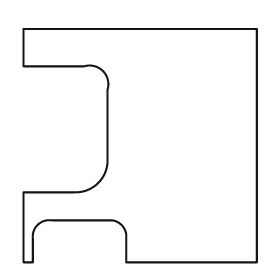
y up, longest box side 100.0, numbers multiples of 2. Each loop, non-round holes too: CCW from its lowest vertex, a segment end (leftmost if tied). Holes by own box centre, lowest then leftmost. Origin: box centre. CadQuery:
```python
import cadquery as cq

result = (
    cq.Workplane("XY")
    .moveTo(-50.0, -50.0)
    .lineTo(-46.0, -50.0)
    .lineTo(-46.0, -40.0)
    .threePointArc((-44.0, -34.0), (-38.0, -32.0))
    .lineTo(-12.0, -32.0)
    .threePointArc((-8.0, -34.0), (-6.0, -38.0))
    .lineTo(-6.0, -50.0)
    .lineTo(50.0, -50.0)
    .lineTo(50.0, 50.0)
    .lineTo(-50.0, 50.0)
    .lineTo(-50.0, 34.0)
    .lineTo(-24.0, 34.0)
    .threePointArc((-16.0, 32.0), (-14.0, 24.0))
    .lineTo(-14.0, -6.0)
    .threePointArc((-18.0, -16.0), (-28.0, -20.0))
    .lineTo(-50.0, -20.0)
    .close()
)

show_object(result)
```